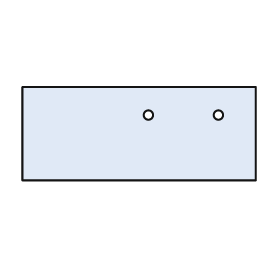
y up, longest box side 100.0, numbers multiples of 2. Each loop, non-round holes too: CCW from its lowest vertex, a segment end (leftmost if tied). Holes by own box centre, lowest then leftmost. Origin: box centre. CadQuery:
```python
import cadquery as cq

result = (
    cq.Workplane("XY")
    .moveTo(-50.0, -20.0)
    .lineTo(50.0, -20.0)
    .lineTo(50.0, 20.0)
    .lineTo(-50.0, 20.0)
    .close()
    .moveTo(4.0, 8.0)
    .circle(2.0)
    .moveTo(34.0, 8.0)
    .circle(2.0)
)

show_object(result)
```